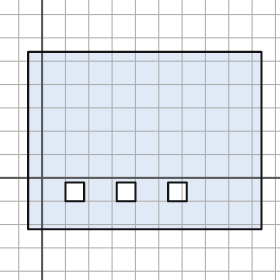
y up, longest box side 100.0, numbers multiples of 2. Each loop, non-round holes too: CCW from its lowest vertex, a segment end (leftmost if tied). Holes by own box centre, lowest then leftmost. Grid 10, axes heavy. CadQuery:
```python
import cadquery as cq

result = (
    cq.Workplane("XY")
    .moveTo(-6.0, -22.0)
    .lineTo(94.0, -22.0)
    .lineTo(94.0, 54.0)
    .lineTo(-6.0, 54.0)
    .close()
    .moveTo(10.0, -10.0)
    .lineTo(18.0, -10.0)
    .lineTo(18.0, -2.0)
    .lineTo(10.0, -2.0)
    .close()
    .moveTo(32.0, -10.0)
    .lineTo(40.0, -10.0)
    .lineTo(40.0, -2.0)
    .lineTo(32.0, -2.0)
    .close()
    .moveTo(54.0, -10.0)
    .lineTo(62.0, -10.0)
    .lineTo(62.0, -2.0)
    .lineTo(54.0, -2.0)
    .close()
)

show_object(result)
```